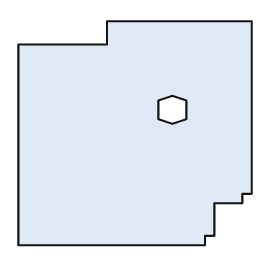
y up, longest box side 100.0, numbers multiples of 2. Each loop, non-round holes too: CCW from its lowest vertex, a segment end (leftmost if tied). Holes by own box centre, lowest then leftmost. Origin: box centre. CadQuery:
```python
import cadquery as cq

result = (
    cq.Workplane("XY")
    .moveTo(-50.0, -48.0)
    .lineTo(30.0, -48.0)
    .lineTo(30.0, -44.0)
    .lineTo(34.0, -44.0)
    .lineTo(34.0, -30.0)
    .lineTo(46.0, -30.0)
    .lineTo(46.0, -26.0)
    .lineTo(50.0, -26.0)
    .lineTo(50.0, 48.0)
    .lineTo(-12.0, 48.0)
    .lineTo(-12.0, 38.0)
    .lineTo(-50.0, 38.0)
    .close()
    .moveTo(16.0, 4.0)
    .lineTo(22.0, 6.0)
    .lineTo(22.0, 14.0)
    .lineTo(16.0, 16.0)
    .lineTo(10.0, 14.0)
    .lineTo(10.0, 6.0)
    .close()
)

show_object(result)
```